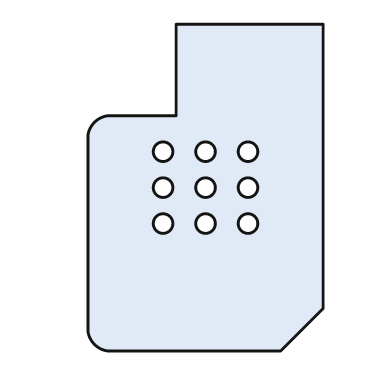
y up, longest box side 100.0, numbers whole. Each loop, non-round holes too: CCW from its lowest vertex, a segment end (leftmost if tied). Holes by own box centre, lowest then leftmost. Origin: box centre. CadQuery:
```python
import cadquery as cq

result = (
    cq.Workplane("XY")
    .moveTo(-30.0, -50.0)
    .lineTo(23.0, -50.0)
    .lineTo(36.0, -37.0)
    .lineTo(36.0, 50.0)
    .lineTo(-9.0, 50.0)
    .lineTo(-9.0, 22.0)
    .lineTo(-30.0, 22.0)
    .threePointArc((-34.0, 20.0), (-36.0, 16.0))
    .lineTo(-36.0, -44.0)
    .threePointArc((-34.0, -48.0), (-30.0, -50.0))
    .close()
    .moveTo(-13.0, -11.0)
    .circle(3.0)
    .moveTo(0.0, -11.0)
    .circle(3.0)
    .moveTo(13.0, -11.0)
    .circle(3.0)
    .moveTo(-13.0, 0.0)
    .circle(3.0)
    .moveTo(0.0, 0.0)
    .circle(3.0)
    .moveTo(13.0, 0.0)
    .circle(3.0)
    .moveTo(-13.0, 11.0)
    .circle(3.0)
    .moveTo(0.0, 11.0)
    .circle(3.0)
    .moveTo(13.0, 11.0)
    .circle(3.0)
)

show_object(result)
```